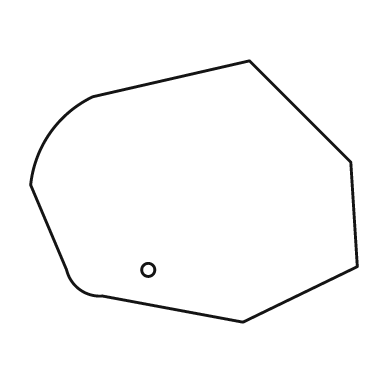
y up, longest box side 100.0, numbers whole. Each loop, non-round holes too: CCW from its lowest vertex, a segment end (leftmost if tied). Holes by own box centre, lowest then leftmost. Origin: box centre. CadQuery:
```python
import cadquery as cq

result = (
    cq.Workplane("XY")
    .moveTo(15.0, -40.0)
    .lineTo(50.0, -23.0)
    .lineTo(48.0, 9.0)
    .lineTo(17.0, 40.0)
    .lineTo(-31.0, 29.0)
    .threePointArc((-44.0, 18.0), (-50.0, 2.0))
    .lineTo(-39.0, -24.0)
    .threePointArc((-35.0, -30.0), (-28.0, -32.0))
    .close()
    .moveTo(-14.0, -24.0)
    .circle(2.0)
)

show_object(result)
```